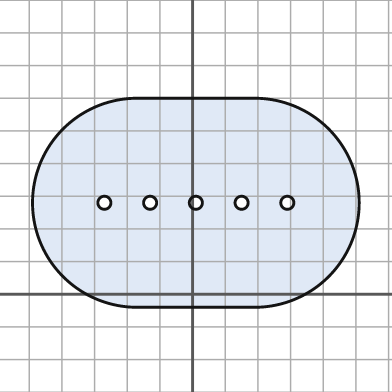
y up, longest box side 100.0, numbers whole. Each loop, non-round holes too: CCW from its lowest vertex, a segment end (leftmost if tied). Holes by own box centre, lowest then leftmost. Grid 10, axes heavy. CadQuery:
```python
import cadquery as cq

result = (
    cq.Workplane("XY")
    .moveTo(-17.0, -4.0)
    .lineTo(19.0, -4.0)
    .threePointArc((51.0, 28.0), (19.0, 60.0))
    .lineTo(-17.0, 60.0)
    .threePointArc((-49.0, 28.0), (-17.0, -4.0))
    .close()
    .moveTo(-27.0, 28.0)
    .circle(2.0)
    .moveTo(-13.0, 28.0)
    .circle(2.0)
    .moveTo(1.0, 28.0)
    .circle(2.0)
    .moveTo(15.0, 28.0)
    .circle(2.0)
    .moveTo(29.0, 28.0)
    .circle(2.0)
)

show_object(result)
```